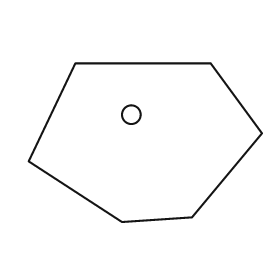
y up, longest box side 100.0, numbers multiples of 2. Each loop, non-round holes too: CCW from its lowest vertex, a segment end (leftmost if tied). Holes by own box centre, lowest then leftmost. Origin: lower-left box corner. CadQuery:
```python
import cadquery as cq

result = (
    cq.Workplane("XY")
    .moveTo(40.0, 0.0)
    .lineTo(70.0, 2.0)
    .lineTo(100.0, 38.0)
    .lineTo(78.0, 68.0)
    .lineTo(20.0, 68.0)
    .lineTo(0.0, 26.0)
    .close()
    .moveTo(44.0, 46.0)
    .circle(4.0)
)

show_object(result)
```